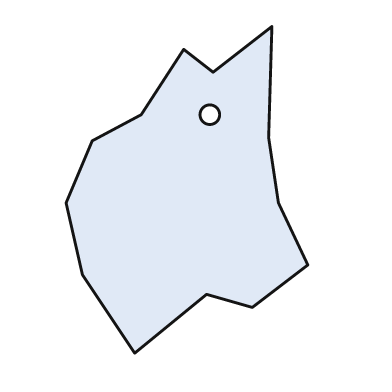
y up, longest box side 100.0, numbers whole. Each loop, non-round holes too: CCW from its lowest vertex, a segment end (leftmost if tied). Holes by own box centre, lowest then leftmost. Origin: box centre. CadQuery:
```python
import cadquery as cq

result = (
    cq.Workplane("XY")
    .moveTo(-16.0, -50.0)
    .lineTo(6.0, -32.0)
    .lineTo(20.0, -36.0)
    .lineTo(37.0, -23.0)
    .lineTo(28.0, -4.0)
    .lineTo(25.0, 16.0)
    .lineTo(26.0, 50.0)
    .lineTo(8.0, 36.0)
    .lineTo(-1.0, 43.0)
    .lineTo(-14.0, 23.0)
    .lineTo(-29.0, 15.0)
    .lineTo(-37.0, -4.0)
    .lineTo(-32.0, -26.0)
    .close()
    .moveTo(7.0, 23.0)
    .circle(3.0)
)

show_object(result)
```